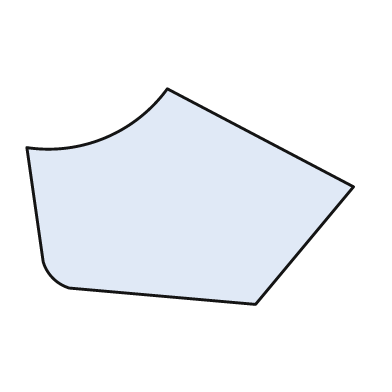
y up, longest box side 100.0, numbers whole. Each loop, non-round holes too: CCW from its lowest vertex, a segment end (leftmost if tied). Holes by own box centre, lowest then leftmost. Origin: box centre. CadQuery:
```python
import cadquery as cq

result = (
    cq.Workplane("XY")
    .moveTo(20.0, -33.0)
    .lineTo(50.0, 3.0)
    .lineTo(-7.0, 33.0)
    .threePointArc((-26.0, 18.0), (-50.0, 15.0))
    .lineTo(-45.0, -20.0)
    .threePointArc((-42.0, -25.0), (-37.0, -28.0))
    .close()
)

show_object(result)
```